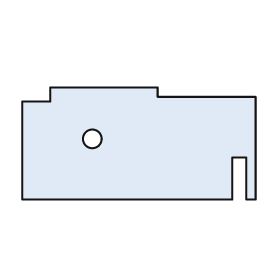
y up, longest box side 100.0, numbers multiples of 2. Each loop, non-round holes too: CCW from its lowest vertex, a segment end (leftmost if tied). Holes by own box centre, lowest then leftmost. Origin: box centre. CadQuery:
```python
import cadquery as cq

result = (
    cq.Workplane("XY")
    .moveTo(-50.0, -24.0)
    .lineTo(40.0, -24.0)
    .lineTo(40.0, -6.0)
    .lineTo(46.0, -6.0)
    .lineTo(46.0, -24.0)
    .lineTo(50.0, -24.0)
    .lineTo(50.0, 20.0)
    .lineTo(8.0, 20.0)
    .lineTo(8.0, 24.0)
    .lineTo(-38.0, 24.0)
    .lineTo(-38.0, 18.0)
    .lineTo(-50.0, 18.0)
    .close()
    .moveTo(-20.0, 2.0)
    .circle(4.0)
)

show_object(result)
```